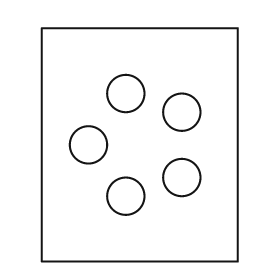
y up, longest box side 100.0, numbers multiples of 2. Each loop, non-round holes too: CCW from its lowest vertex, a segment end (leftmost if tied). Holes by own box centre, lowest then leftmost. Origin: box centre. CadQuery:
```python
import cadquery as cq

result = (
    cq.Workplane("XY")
    .moveTo(-42.0, -50.0)
    .lineTo(42.0, -50.0)
    .lineTo(42.0, 50.0)
    .lineTo(-42.0, 50.0)
    .close()
    .moveTo(-6.0, -22.0)
    .circle(8.0)
    .moveTo(18.0, -14.0)
    .circle(8.0)
    .moveTo(-22.0, 0.0)
    .circle(8.0)
    .moveTo(18.0, 14.0)
    .circle(8.0)
    .moveTo(-6.0, 22.0)
    .circle(8.0)
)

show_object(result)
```